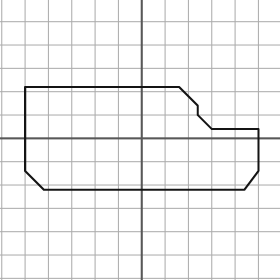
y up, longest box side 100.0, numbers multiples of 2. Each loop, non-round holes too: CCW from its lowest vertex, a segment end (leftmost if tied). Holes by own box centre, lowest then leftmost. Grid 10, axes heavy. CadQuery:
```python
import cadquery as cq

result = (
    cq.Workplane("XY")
    .moveTo(-42.0, -22.0)
    .lineTo(44.0, -22.0)
    .lineTo(50.0, -14.0)
    .lineTo(50.0, 4.0)
    .lineTo(30.0, 4.0)
    .lineTo(24.0, 10.0)
    .lineTo(24.0, 14.0)
    .lineTo(16.0, 22.0)
    .lineTo(-50.0, 22.0)
    .lineTo(-50.0, -14.0)
    .close()
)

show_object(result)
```